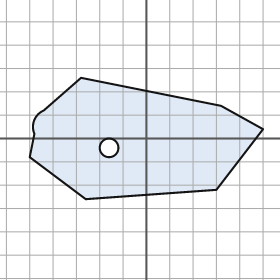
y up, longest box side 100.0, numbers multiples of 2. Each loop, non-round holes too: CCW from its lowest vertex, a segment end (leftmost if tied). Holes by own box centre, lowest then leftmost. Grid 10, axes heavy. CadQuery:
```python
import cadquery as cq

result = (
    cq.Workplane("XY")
    .moveTo(-26.0, -26.0)
    .lineTo(30.0, -22.0)
    .lineTo(50.0, 4.0)
    .lineTo(32.0, 14.0)
    .lineTo(-28.0, 26.0)
    .lineTo(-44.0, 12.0)
    .threePointArc((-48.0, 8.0), (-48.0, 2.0))
    .lineTo(-50.0, -8.0)
    .close()
    .moveTo(-16.0, -4.0)
    .circle(4.0)
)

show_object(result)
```